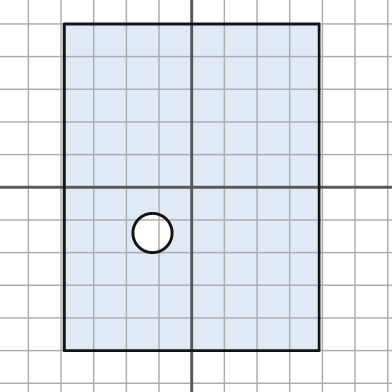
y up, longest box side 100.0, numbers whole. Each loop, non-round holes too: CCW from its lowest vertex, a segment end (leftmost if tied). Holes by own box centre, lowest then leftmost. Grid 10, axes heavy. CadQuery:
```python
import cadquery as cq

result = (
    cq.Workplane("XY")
    .moveTo(-39.0, -50.0)
    .lineTo(39.0, -50.0)
    .lineTo(39.0, 50.0)
    .lineTo(-39.0, 50.0)
    .close()
    .moveTo(-12.0, -14.0)
    .circle(6.0)
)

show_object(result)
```